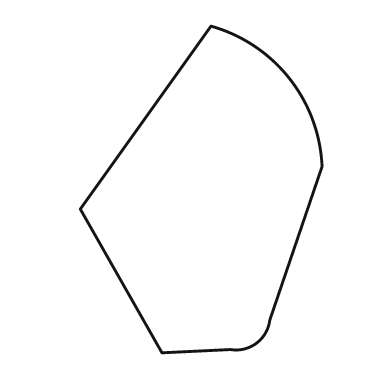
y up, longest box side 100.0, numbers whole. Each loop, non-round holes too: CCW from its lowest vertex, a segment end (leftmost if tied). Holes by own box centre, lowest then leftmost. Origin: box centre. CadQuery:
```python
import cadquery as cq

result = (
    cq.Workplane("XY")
    .moveTo(-12.0, -50.0)
    .lineTo(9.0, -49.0)
    .threePointArc((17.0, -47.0), (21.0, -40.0))
    .lineTo(37.0, 7.0)
    .threePointArc((27.0, 34.0), (3.0, 50.0))
    .lineTo(-37.0, -6.0)
    .close()
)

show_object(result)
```